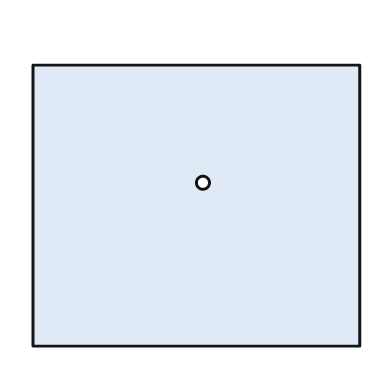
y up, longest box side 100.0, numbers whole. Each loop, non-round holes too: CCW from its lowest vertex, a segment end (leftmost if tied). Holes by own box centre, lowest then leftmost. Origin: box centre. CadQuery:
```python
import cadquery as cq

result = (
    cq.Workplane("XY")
    .moveTo(-50.0, -43.0)
    .lineTo(50.0, -43.0)
    .lineTo(50.0, 43.0)
    .lineTo(-50.0, 43.0)
    .close()
    .moveTo(2.0, 7.0)
    .circle(2.0)
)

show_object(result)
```